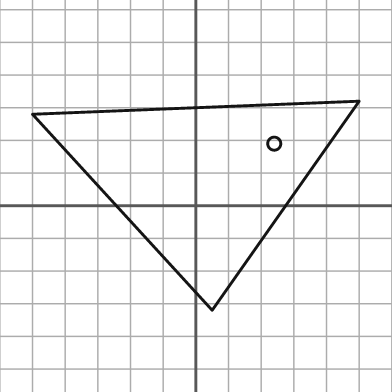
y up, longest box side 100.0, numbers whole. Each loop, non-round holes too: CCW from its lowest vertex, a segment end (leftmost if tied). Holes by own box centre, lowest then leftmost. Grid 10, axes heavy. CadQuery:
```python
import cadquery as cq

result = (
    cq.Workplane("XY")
    .moveTo(5.0, -32.0)
    .lineTo(50.0, 32.0)
    .lineTo(-50.0, 28.0)
    .close()
    .moveTo(24.0, 19.0)
    .circle(2.0)
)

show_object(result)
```